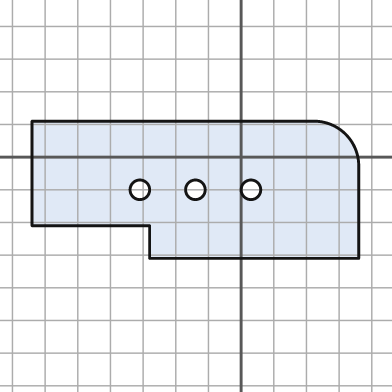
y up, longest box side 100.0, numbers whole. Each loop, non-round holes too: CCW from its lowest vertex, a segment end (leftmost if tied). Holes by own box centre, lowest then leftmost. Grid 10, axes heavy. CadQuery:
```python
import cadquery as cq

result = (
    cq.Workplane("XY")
    .moveTo(-28.0, -31.0)
    .lineTo(36.0, -31.0)
    .lineTo(36.0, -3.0)
    .threePointArc((32.0, 7.0), (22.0, 11.0))
    .lineTo(-64.0, 11.0)
    .lineTo(-64.0, -21.0)
    .lineTo(-28.0, -21.0)
    .close()
    .moveTo(-31.0, -10.0)
    .circle(3.0)
    .moveTo(-14.0, -10.0)
    .circle(3.0)
    .moveTo(3.0, -10.0)
    .circle(3.0)
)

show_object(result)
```